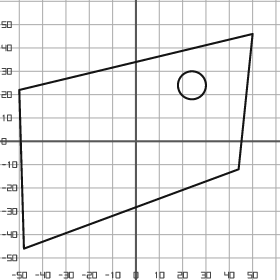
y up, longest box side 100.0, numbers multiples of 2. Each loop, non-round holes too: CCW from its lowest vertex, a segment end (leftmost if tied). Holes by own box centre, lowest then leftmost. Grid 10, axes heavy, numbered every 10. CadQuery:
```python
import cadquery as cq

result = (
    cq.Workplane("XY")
    .moveTo(-48.0, -46.0)
    .lineTo(44.0, -12.0)
    .lineTo(50.0, 46.0)
    .lineTo(-50.0, 22.0)
    .close()
    .moveTo(24.0, 24.0)
    .circle(6.0)
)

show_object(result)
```